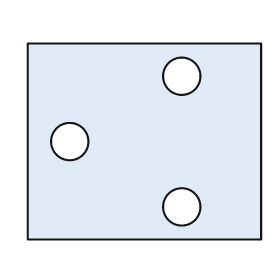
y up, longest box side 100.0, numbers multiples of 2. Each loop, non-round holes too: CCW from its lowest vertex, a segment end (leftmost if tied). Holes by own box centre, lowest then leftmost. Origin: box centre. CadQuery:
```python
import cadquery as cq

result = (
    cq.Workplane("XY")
    .moveTo(-50.0, -42.0)
    .lineTo(50.0, -42.0)
    .lineTo(50.0, 42.0)
    .lineTo(-50.0, 42.0)
    .close()
    .moveTo(16.0, -28.0)
    .circle(8.0)
    .moveTo(-32.0, 0.0)
    .circle(8.0)
    .moveTo(16.0, 28.0)
    .circle(8.0)
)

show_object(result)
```